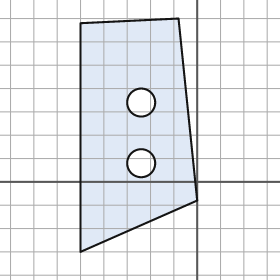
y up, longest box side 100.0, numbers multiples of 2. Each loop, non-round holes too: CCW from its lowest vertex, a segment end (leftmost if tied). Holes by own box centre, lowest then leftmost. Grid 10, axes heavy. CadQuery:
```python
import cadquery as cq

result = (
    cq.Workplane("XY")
    .moveTo(-50.0, -30.0)
    .lineTo(0.0, -8.0)
    .lineTo(-8.0, 70.0)
    .lineTo(-50.0, 68.0)
    .close()
    .moveTo(-24.0, 8.0)
    .circle(6.0)
    .moveTo(-24.0, 34.0)
    .circle(6.0)
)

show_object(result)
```